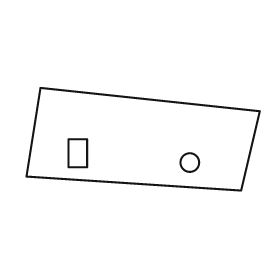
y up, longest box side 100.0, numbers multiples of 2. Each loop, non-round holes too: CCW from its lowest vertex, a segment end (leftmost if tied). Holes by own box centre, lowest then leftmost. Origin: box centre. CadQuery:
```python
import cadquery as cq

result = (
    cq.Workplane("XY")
    .moveTo(42.0, -22.0)
    .lineTo(50.0, 12.0)
    .lineTo(-44.0, 22.0)
    .lineTo(-50.0, -16.0)
    .close()
    .moveTo(20.0, -10.0)
    .circle(4.0)
    .moveTo(-32.0, -12.0)
    .lineTo(-24.0, -12.0)
    .lineTo(-24.0, 0.0)
    .lineTo(-32.0, 0.0)
    .close()
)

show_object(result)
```